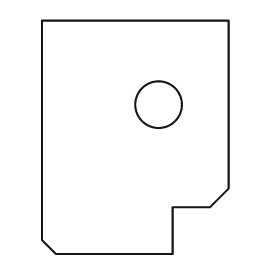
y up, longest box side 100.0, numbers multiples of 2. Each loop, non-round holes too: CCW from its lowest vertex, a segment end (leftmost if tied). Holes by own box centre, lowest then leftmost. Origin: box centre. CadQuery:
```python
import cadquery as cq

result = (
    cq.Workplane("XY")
    .moveTo(-34.0, -50.0)
    .lineTo(16.0, -50.0)
    .lineTo(16.0, -30.0)
    .lineTo(32.0, -30.0)
    .lineTo(40.0, -22.0)
    .lineTo(40.0, 50.0)
    .lineTo(-40.0, 50.0)
    .lineTo(-40.0, -44.0)
    .close()
    .moveTo(10.0, 14.0)
    .circle(10.0)
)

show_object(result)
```